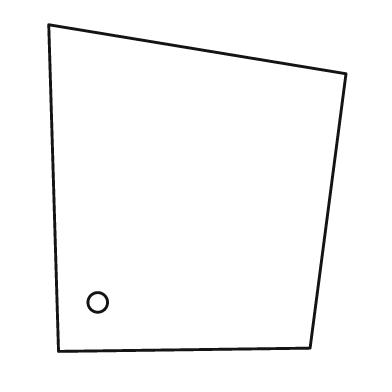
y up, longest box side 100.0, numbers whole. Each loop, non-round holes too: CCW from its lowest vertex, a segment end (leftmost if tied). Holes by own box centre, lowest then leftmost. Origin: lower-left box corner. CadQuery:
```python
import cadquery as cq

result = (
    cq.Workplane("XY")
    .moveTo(3.0, 0.0)
    .lineTo(80.0, 1.0)
    .lineTo(91.0, 85.0)
    .lineTo(0.0, 100.0)
    .close()
    .moveTo(15.0, 15.0)
    .circle(3.0)
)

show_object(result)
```